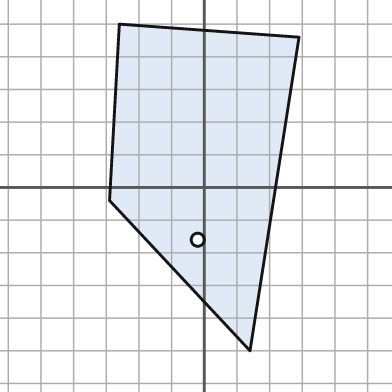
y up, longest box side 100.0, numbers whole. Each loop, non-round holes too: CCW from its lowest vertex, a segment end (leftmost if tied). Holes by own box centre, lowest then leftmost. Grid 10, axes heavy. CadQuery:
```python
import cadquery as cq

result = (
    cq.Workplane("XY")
    .moveTo(14.0, -50.0)
    .lineTo(29.0, 46.0)
    .lineTo(-26.0, 50.0)
    .lineTo(-29.0, -4.0)
    .close()
    .moveTo(-2.0, -16.0)
    .circle(2.0)
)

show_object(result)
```